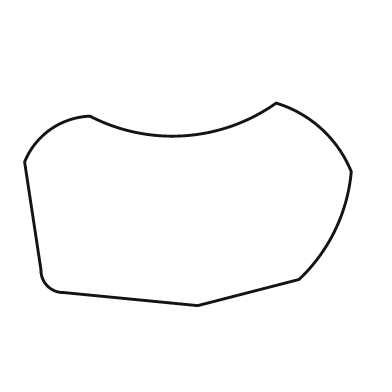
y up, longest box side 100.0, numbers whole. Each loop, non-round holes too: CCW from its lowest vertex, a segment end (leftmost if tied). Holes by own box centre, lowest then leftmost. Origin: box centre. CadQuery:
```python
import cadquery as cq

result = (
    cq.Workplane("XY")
    .moveTo(3.0, -31.0)
    .lineTo(34.0, -23.0)
    .threePointArc((45.0, -8.0), (50.0, 10.0))
    .threePointArc((41.0, 23.0), (27.0, 31.0))
    .threePointArc((-1.0, 21.0), (-30.0, 27.0))
    .threePointArc((-42.0, 23.0), (-50.0, 13.0))
    .lineTo(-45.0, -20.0)
    .threePointArc((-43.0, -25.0), (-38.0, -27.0))
    .close()
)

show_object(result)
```